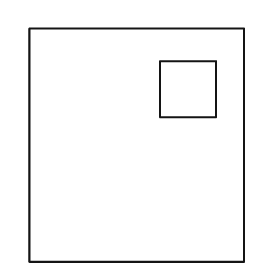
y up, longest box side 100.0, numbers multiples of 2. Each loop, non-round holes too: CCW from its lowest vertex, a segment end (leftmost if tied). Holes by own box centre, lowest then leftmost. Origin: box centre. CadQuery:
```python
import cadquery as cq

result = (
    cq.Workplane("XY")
    .moveTo(-46.0, -50.0)
    .lineTo(46.0, -50.0)
    .lineTo(46.0, 50.0)
    .lineTo(-46.0, 50.0)
    .close()
    .moveTo(10.0, 12.0)
    .lineTo(34.0, 12.0)
    .lineTo(34.0, 36.0)
    .lineTo(10.0, 36.0)
    .close()
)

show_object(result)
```